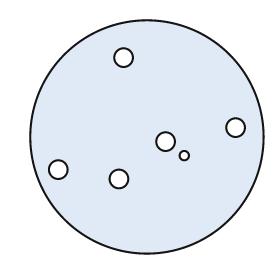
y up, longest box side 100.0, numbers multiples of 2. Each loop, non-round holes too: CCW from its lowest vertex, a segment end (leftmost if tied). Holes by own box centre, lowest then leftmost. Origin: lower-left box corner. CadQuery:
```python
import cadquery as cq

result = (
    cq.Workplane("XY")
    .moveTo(50.0, 50.0)
    .circle(50.0)
    .moveTo(38.0, 32.0)
    .circle(4.0)
    .moveTo(12.0, 36.0)
    .circle(4.0)
    .moveTo(66.0, 42.0)
    .circle(2.0)
    .moveTo(58.0, 48.0)
    .circle(4.0)
    .moveTo(88.0, 54.0)
    .circle(4.0)
    .moveTo(40.0, 84.0)
    .circle(4.0)
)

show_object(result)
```